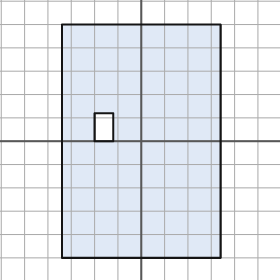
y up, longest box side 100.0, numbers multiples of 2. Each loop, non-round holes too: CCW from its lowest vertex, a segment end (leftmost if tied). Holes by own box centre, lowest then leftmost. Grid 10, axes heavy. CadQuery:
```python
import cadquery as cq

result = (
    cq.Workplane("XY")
    .moveTo(-34.0, -50.0)
    .lineTo(34.0, -50.0)
    .lineTo(34.0, 50.0)
    .lineTo(-34.0, 50.0)
    .close()
    .moveTo(-20.0, 0.0)
    .lineTo(-12.0, 0.0)
    .lineTo(-12.0, 12.0)
    .lineTo(-20.0, 12.0)
    .close()
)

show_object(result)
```